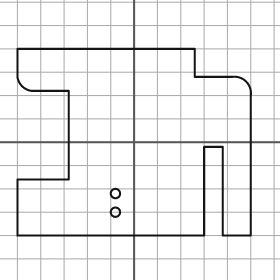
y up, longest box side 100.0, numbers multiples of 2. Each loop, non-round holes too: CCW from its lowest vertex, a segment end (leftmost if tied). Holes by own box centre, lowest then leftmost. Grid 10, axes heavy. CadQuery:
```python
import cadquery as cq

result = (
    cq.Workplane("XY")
    .moveTo(-50.0, -40.0)
    .lineTo(30.0, -40.0)
    .lineTo(30.0, -2.0)
    .lineTo(38.0, -2.0)
    .lineTo(38.0, -40.0)
    .lineTo(50.0, -40.0)
    .lineTo(50.0, 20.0)
    .threePointArc((48.0, 26.0), (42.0, 28.0))
    .lineTo(26.0, 28.0)
    .lineTo(26.0, 40.0)
    .lineTo(-50.0, 40.0)
    .lineTo(-50.0, 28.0)
    .threePointArc((-48.0, 24.0), (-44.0, 22.0))
    .lineTo(-28.0, 22.0)
    .lineTo(-28.0, -16.0)
    .lineTo(-50.0, -16.0)
    .close()
    .moveTo(-8.0, -30.0)
    .circle(2.0)
    .moveTo(-8.0, -22.0)
    .circle(2.0)
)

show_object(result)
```